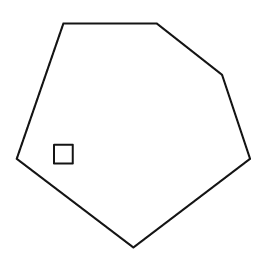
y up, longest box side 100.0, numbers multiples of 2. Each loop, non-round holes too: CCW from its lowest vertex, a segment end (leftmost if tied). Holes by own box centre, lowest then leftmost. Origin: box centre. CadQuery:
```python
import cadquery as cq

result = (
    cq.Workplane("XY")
    .moveTo(0.0, -48.0)
    .lineTo(50.0, -10.0)
    .lineTo(38.0, 26.0)
    .lineTo(10.0, 48.0)
    .lineTo(-30.0, 48.0)
    .lineTo(-50.0, -10.0)
    .close()
    .moveTo(-34.0, -12.0)
    .lineTo(-26.0, -12.0)
    .lineTo(-26.0, -4.0)
    .lineTo(-34.0, -4.0)
    .close()
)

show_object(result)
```